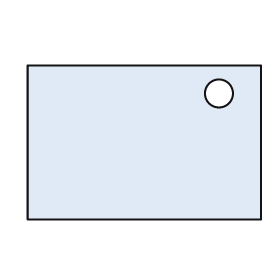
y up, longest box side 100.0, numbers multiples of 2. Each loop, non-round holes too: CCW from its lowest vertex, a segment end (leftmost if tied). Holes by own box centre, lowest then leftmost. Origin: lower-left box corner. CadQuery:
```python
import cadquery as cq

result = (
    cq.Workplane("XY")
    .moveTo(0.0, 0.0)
    .lineTo(100.0, 0.0)
    .lineTo(100.0, 66.0)
    .lineTo(0.0, 66.0)
    .close()
    .moveTo(82.0, 54.0)
    .circle(6.0)
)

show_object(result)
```